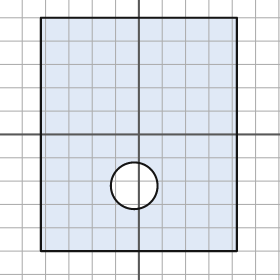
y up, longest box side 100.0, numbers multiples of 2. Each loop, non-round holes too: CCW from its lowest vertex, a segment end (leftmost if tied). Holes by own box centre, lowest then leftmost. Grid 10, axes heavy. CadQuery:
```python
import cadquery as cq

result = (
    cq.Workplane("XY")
    .moveTo(-42.0, -50.0)
    .lineTo(42.0, -50.0)
    .lineTo(42.0, 50.0)
    .lineTo(-42.0, 50.0)
    .close()
    .moveTo(-2.0, -22.0)
    .circle(10.0)
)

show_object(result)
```